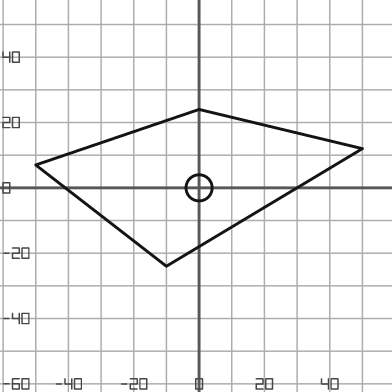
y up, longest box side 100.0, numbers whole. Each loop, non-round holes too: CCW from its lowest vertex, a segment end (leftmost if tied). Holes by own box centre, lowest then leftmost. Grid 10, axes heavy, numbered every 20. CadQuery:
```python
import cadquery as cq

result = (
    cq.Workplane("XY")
    .moveTo(-10.0, -24.0)
    .lineTo(50.0, 12.0)
    .lineTo(0.0, 24.0)
    .lineTo(-50.0, 7.0)
    .close()
    .moveTo(0.0, 0.0)
    .circle(4.0)
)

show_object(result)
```